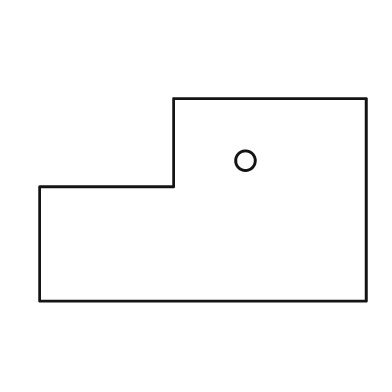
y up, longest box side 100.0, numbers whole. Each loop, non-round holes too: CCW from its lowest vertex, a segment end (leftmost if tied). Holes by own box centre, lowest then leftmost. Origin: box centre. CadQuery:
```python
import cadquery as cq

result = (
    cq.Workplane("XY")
    .moveTo(-50.0, -31.0)
    .lineTo(50.0, -31.0)
    .lineTo(50.0, 31.0)
    .lineTo(-9.0, 31.0)
    .lineTo(-9.0, 4.0)
    .lineTo(-50.0, 4.0)
    .close()
    .moveTo(13.0, 12.0)
    .circle(3.0)
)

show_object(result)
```